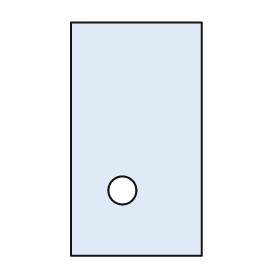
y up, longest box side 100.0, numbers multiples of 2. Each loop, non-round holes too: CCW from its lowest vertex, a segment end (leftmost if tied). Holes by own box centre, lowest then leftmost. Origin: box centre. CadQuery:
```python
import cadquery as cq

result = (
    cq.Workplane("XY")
    .moveTo(-28.0, -50.0)
    .lineTo(28.0, -50.0)
    .lineTo(28.0, 50.0)
    .lineTo(-28.0, 50.0)
    .close()
    .moveTo(-6.0, -22.0)
    .circle(6.0)
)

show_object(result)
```